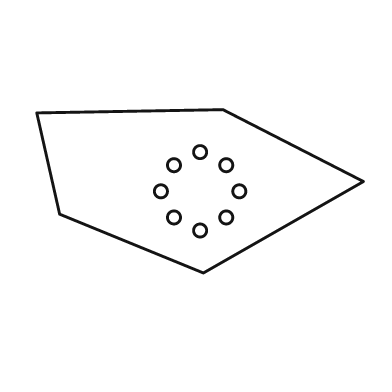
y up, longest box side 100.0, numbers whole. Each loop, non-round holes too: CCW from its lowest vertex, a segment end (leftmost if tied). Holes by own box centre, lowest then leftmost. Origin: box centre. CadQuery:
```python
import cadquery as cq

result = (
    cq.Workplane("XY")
    .moveTo(1.0, -25.0)
    .lineTo(50.0, 3.0)
    .lineTo(7.0, 25.0)
    .lineTo(-50.0, 24.0)
    .lineTo(-43.0, -7.0)
    .close()
    .moveTo(0.0, -12.0)
    .circle(2.0)
    .moveTo(-8.0, -8.0)
    .circle(2.0)
    .moveTo(8.0, -8.0)
    .circle(2.0)
    .moveTo(-12.0, 0.0)
    .circle(2.0)
    .moveTo(12.0, 0.0)
    .circle(2.0)
    .moveTo(-8.0, 8.0)
    .circle(2.0)
    .moveTo(8.0, 8.0)
    .circle(2.0)
    .moveTo(0.0, 12.0)
    .circle(2.0)
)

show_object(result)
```